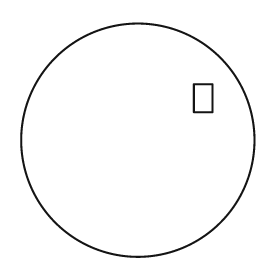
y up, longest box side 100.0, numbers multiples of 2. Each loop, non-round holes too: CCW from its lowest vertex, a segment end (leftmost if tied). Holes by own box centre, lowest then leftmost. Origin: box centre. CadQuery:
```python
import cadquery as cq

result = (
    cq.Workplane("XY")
    .moveTo(0.0, 0.0)
    .circle(50.0)
    .moveTo(24.0, 12.0)
    .lineTo(32.0, 12.0)
    .lineTo(32.0, 24.0)
    .lineTo(24.0, 24.0)
    .close()
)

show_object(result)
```